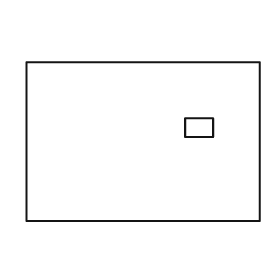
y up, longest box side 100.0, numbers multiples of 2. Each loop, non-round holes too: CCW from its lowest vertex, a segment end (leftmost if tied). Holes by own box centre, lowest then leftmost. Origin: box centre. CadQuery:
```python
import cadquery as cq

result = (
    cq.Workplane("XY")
    .moveTo(-50.0, -34.0)
    .lineTo(50.0, -34.0)
    .lineTo(50.0, 34.0)
    .lineTo(-50.0, 34.0)
    .close()
    .moveTo(18.0, 2.0)
    .lineTo(30.0, 2.0)
    .lineTo(30.0, 10.0)
    .lineTo(18.0, 10.0)
    .close()
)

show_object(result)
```